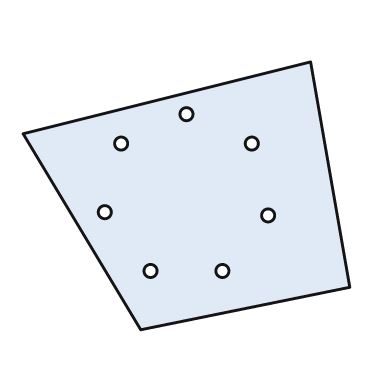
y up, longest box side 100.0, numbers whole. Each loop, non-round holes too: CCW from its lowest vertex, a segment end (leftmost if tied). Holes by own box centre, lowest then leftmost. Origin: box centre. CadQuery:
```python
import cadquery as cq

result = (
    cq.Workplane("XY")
    .moveTo(-14.0, -41.0)
    .lineTo(50.0, -28.0)
    .lineTo(38.0, 41.0)
    .lineTo(-50.0, 19.0)
    .close()
    .moveTo(-11.0, -23.0)
    .circle(2.0)
    .moveTo(11.0, -23.0)
    .circle(2.0)
    .moveTo(25.0, -6.0)
    .circle(2.0)
    .moveTo(-25.0, -5.0)
    .circle(2.0)
    .moveTo(-20.0, 16.0)
    .circle(2.0)
    .moveTo(20.0, 16.0)
    .circle(2.0)
    .moveTo(0.0, 25.0)
    .circle(2.0)
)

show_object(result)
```